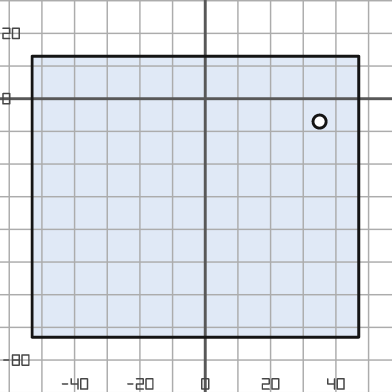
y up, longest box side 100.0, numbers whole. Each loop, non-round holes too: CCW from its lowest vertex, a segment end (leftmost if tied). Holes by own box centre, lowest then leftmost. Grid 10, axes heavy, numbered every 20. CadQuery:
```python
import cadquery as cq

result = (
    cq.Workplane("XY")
    .moveTo(-53.0, -73.0)
    .lineTo(47.0, -73.0)
    .lineTo(47.0, 13.0)
    .lineTo(-53.0, 13.0)
    .close()
    .moveTo(35.0, -7.0)
    .circle(2.0)
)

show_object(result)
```